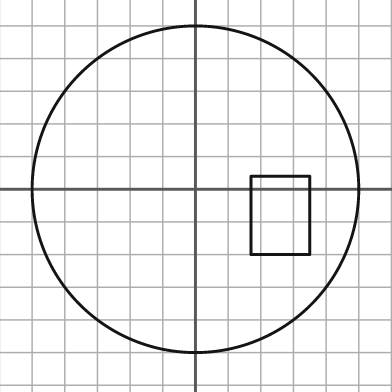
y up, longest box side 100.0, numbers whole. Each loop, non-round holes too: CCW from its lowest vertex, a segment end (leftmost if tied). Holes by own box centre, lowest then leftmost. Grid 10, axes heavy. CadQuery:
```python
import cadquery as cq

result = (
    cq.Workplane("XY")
    .moveTo(0.0, 0.0)
    .circle(50.0)
    .moveTo(17.0, -20.0)
    .lineTo(35.0, -20.0)
    .lineTo(35.0, 4.0)
    .lineTo(17.0, 4.0)
    .close()
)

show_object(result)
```